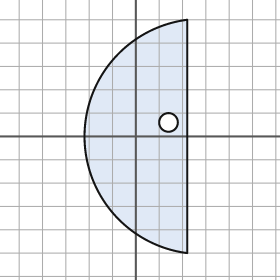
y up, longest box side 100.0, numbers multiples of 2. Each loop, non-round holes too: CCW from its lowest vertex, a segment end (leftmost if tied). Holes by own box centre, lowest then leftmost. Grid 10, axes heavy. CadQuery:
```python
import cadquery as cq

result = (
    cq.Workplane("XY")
    .moveTo(22.0, -50.0)
    .lineTo(22.0, 50.0)
    .threePointArc((-22.0, 0.0), (22.0, -50.0))
    .close()
    .moveTo(14.0, 6.0)
    .circle(4.0)
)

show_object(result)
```